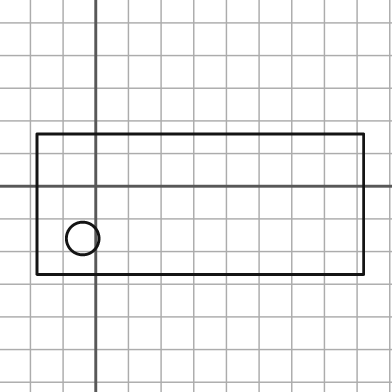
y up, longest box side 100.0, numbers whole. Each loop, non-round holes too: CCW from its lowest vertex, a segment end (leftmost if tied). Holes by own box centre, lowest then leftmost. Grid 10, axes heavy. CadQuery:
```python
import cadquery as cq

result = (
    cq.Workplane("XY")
    .moveTo(-18.0, -27.0)
    .lineTo(82.0, -27.0)
    .lineTo(82.0, 16.0)
    .lineTo(-18.0, 16.0)
    .close()
    .moveTo(-4.0, -16.0)
    .circle(5.0)
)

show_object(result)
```